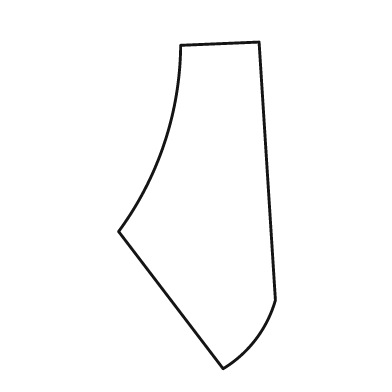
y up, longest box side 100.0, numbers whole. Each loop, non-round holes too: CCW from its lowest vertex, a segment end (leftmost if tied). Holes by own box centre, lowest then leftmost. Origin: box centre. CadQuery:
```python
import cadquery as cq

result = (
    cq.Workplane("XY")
    .moveTo(8.0, -50.0)
    .threePointArc((18.0, -41.0), (24.0, -29.0))
    .lineTo(19.0, 50.0)
    .lineTo(-5.0, 49.0)
    .threePointArc((-10.0, 19.0), (-24.0, -8.0))
    .close()
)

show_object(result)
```